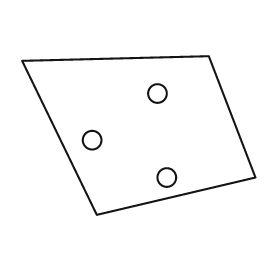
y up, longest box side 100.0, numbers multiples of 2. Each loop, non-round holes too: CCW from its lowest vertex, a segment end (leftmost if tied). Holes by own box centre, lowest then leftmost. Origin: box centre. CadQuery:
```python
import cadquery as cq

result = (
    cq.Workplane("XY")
    .moveTo(-18.0, -34.0)
    .lineTo(50.0, -18.0)
    .lineTo(30.0, 34.0)
    .lineTo(-50.0, 32.0)
    .close()
    .moveTo(12.0, -18.0)
    .circle(4.0)
    .moveTo(-20.0, -2.0)
    .circle(4.0)
    .moveTo(8.0, 18.0)
    .circle(4.0)
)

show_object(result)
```